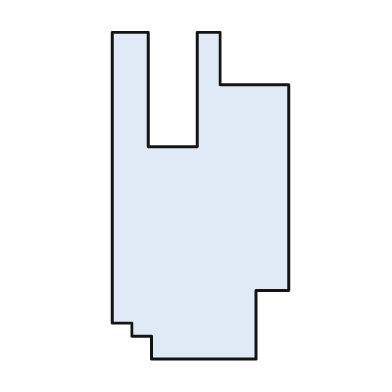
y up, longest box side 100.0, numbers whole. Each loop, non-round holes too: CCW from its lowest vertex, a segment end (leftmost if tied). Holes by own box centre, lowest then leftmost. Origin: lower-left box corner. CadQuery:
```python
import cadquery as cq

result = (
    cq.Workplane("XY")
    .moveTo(12.0, 0.0)
    .lineTo(44.0, 0.0)
    .lineTo(44.0, 21.0)
    .lineTo(54.0, 21.0)
    .lineTo(54.0, 84.0)
    .lineTo(33.0, 84.0)
    .lineTo(33.0, 100.0)
    .lineTo(26.0, 100.0)
    .lineTo(26.0, 65.0)
    .lineTo(11.0, 65.0)
    .lineTo(11.0, 100.0)
    .lineTo(0.0, 100.0)
    .lineTo(0.0, 11.0)
    .lineTo(6.0, 11.0)
    .lineTo(6.0, 7.0)
    .lineTo(12.0, 7.0)
    .close()
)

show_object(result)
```